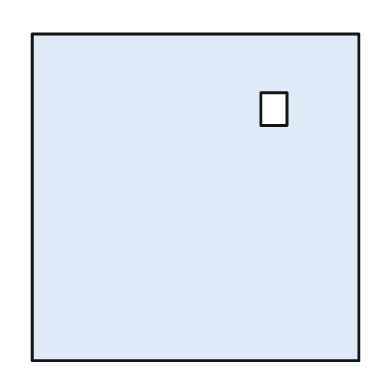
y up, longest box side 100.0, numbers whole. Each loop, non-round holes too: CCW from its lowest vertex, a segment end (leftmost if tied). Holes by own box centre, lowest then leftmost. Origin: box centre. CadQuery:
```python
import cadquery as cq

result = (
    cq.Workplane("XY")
    .moveTo(-50.0, -50.0)
    .lineTo(50.0, -50.0)
    .lineTo(50.0, 50.0)
    .lineTo(-50.0, 50.0)
    .close()
    .moveTo(20.0, 22.0)
    .lineTo(28.0, 22.0)
    .lineTo(28.0, 32.0)
    .lineTo(20.0, 32.0)
    .close()
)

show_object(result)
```